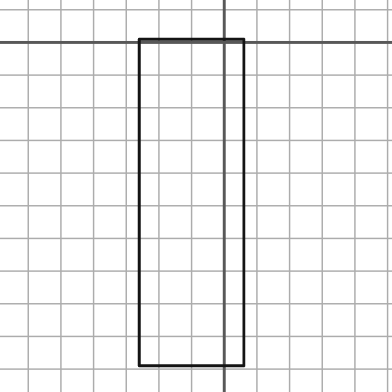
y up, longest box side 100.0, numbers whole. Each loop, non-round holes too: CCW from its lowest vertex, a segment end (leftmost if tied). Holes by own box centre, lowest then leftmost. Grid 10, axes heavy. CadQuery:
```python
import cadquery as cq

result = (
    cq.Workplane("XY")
    .moveTo(-26.0, -99.0)
    .lineTo(6.0, -99.0)
    .lineTo(6.0, 1.0)
    .lineTo(-26.0, 1.0)
    .close()
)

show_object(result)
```